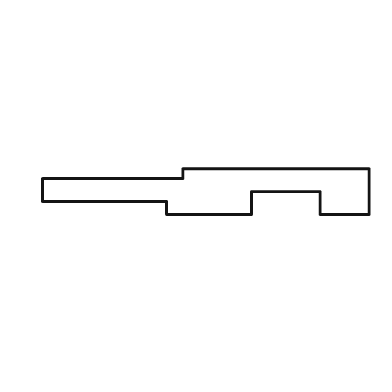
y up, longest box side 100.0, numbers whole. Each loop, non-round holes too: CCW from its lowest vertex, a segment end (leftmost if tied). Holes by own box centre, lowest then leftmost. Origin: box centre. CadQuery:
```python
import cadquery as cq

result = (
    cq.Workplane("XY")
    .moveTo(-12.0, -7.0)
    .lineTo(14.0, -7.0)
    .lineTo(14.0, 0.0)
    .lineTo(35.0, 0.0)
    .lineTo(35.0, -7.0)
    .lineTo(50.0, -7.0)
    .lineTo(50.0, 7.0)
    .lineTo(-7.0, 7.0)
    .lineTo(-7.0, 4.0)
    .lineTo(-50.0, 4.0)
    .lineTo(-50.0, -3.0)
    .lineTo(-12.0, -3.0)
    .close()
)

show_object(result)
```